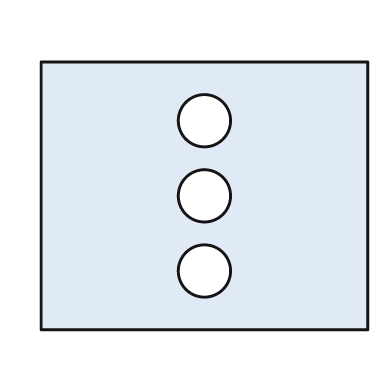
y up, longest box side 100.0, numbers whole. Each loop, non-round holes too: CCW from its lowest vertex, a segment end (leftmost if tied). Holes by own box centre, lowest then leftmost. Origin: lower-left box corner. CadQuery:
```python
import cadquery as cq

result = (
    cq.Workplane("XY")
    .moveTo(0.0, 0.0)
    .lineTo(100.0, 0.0)
    .lineTo(100.0, 82.0)
    .lineTo(0.0, 82.0)
    .close()
    .moveTo(50.0, 18.0)
    .circle(8.0)
    .moveTo(50.0, 41.0)
    .circle(8.0)
    .moveTo(50.0, 64.0)
    .circle(8.0)
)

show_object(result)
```